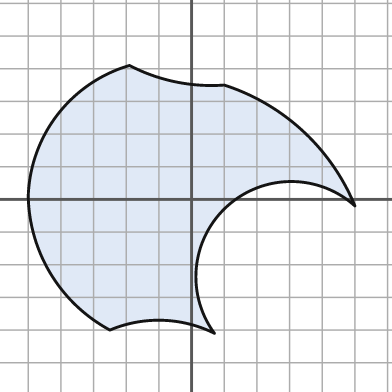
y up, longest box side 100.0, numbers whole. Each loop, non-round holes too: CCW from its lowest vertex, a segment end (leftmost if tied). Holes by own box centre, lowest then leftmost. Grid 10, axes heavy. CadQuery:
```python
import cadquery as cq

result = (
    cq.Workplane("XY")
    .moveTo(7.0, -41.0)
    .threePointArc((11.0, -2.0), (50.0, -2.0))
    .threePointArc((34.0, 21.0), (10.0, 35.0))
    .threePointArc((-5.0, 36.0), (-19.0, 41.0))
    .threePointArc((-41.0, 26.0), (-50.0, 1.0))
    .threePointArc((-43.0, -23.0), (-25.0, -40.0))
    .threePointArc((-9.0, -37.0), (7.0, -41.0))
    .close()
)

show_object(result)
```